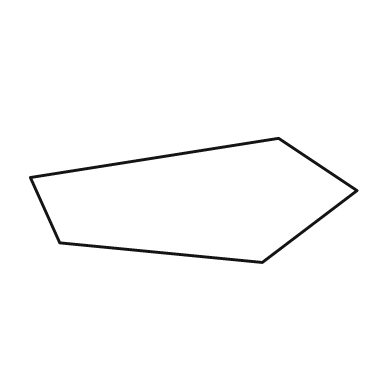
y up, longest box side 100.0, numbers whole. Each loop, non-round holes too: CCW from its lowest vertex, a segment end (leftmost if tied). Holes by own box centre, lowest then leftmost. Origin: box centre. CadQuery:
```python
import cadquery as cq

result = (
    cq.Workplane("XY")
    .moveTo(21.0, -19.0)
    .lineTo(50.0, 3.0)
    .lineTo(26.0, 19.0)
    .lineTo(-50.0, 7.0)
    .lineTo(-41.0, -13.0)
    .close()
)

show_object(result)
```